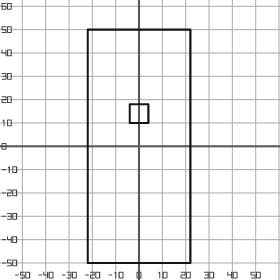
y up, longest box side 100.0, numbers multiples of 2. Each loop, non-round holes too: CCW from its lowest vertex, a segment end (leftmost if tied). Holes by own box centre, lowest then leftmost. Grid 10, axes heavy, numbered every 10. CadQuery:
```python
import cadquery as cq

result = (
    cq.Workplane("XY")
    .moveTo(-22.0, -50.0)
    .lineTo(22.0, -50.0)
    .lineTo(22.0, 50.0)
    .lineTo(-22.0, 50.0)
    .close()
    .moveTo(-4.0, 10.0)
    .lineTo(4.0, 10.0)
    .lineTo(4.0, 18.0)
    .lineTo(-4.0, 18.0)
    .close()
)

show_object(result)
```